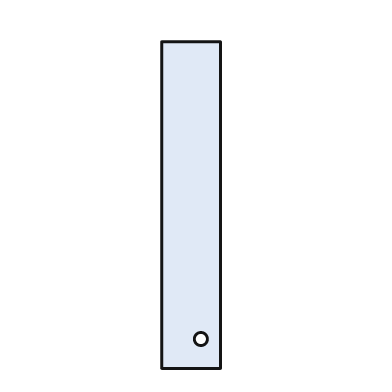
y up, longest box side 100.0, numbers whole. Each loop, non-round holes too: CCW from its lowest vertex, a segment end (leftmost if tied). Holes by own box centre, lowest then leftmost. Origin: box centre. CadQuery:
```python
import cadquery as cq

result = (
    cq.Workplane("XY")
    .moveTo(-9.0, -50.0)
    .lineTo(9.0, -50.0)
    .lineTo(9.0, 50.0)
    .lineTo(-9.0, 50.0)
    .close()
    .moveTo(3.0, -41.0)
    .circle(2.0)
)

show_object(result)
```